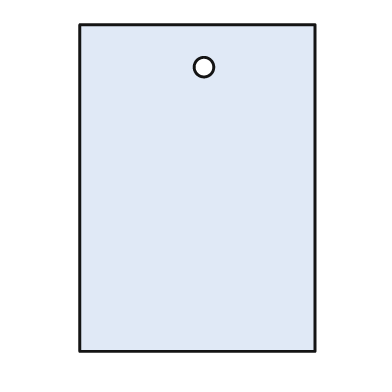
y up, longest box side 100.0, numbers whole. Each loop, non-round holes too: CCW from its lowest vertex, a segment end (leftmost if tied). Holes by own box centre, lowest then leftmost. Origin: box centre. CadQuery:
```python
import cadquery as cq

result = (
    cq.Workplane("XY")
    .moveTo(-36.0, -50.0)
    .lineTo(36.0, -50.0)
    .lineTo(36.0, 50.0)
    .lineTo(-36.0, 50.0)
    .close()
    .moveTo(2.0, 37.0)
    .circle(3.0)
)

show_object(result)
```